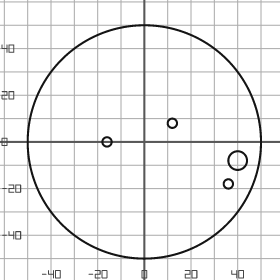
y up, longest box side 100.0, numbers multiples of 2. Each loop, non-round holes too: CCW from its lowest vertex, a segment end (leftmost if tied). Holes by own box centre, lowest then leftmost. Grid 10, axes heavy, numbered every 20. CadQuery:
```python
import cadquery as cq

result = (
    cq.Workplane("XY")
    .moveTo(0.0, 0.0)
    .circle(50.0)
    .moveTo(36.0, -18.0)
    .circle(2.0)
    .moveTo(40.0, -8.0)
    .circle(4.0)
    .moveTo(-16.0, 0.0)
    .circle(2.0)
    .moveTo(12.0, 8.0)
    .circle(2.0)
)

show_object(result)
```